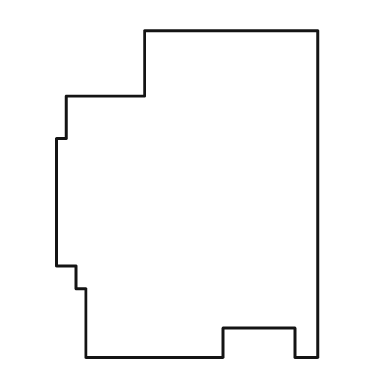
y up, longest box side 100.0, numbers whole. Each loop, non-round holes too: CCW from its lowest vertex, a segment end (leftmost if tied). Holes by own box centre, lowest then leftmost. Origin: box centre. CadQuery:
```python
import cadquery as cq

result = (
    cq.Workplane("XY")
    .moveTo(-31.0, -50.0)
    .lineTo(11.0, -50.0)
    .lineTo(11.0, -41.0)
    .lineTo(33.0, -41.0)
    .lineTo(33.0, -50.0)
    .lineTo(40.0, -50.0)
    .lineTo(40.0, 50.0)
    .lineTo(-13.0, 50.0)
    .lineTo(-13.0, 30.0)
    .lineTo(-37.0, 30.0)
    .lineTo(-37.0, 17.0)
    .lineTo(-40.0, 17.0)
    .lineTo(-40.0, -22.0)
    .lineTo(-34.0, -22.0)
    .lineTo(-34.0, -29.0)
    .lineTo(-31.0, -29.0)
    .close()
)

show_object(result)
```